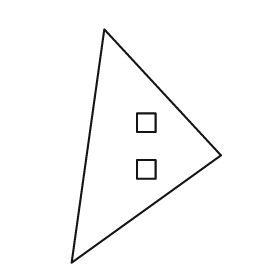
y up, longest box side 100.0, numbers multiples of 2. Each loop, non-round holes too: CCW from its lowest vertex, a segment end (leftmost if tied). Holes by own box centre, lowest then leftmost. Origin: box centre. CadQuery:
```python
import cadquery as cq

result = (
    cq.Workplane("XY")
    .moveTo(-32.0, -50.0)
    .lineTo(32.0, -4.0)
    .lineTo(-18.0, 50.0)
    .close()
    .moveTo(-4.0, -14.0)
    .lineTo(4.0, -14.0)
    .lineTo(4.0, -6.0)
    .lineTo(-4.0, -6.0)
    .close()
    .moveTo(-4.0, 6.0)
    .lineTo(4.0, 6.0)
    .lineTo(4.0, 14.0)
    .lineTo(-4.0, 14.0)
    .close()
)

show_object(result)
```